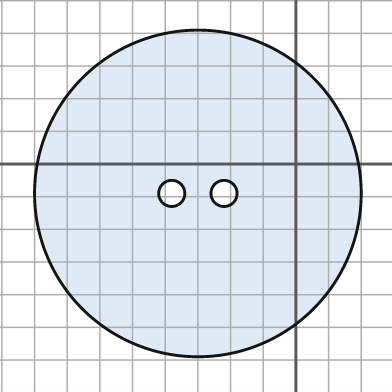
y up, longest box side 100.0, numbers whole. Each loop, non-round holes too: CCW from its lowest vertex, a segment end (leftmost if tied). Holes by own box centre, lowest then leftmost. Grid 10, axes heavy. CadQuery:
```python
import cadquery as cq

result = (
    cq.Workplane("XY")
    .moveTo(-30.0, -9.0)
    .circle(50.0)
    .moveTo(-38.0, -9.0)
    .circle(4.0)
    .moveTo(-22.0, -9.0)
    .circle(4.0)
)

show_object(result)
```